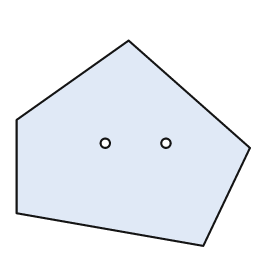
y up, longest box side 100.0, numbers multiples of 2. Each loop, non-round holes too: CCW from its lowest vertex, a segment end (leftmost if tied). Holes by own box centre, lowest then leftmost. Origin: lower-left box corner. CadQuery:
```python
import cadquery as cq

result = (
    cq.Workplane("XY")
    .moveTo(80.0, 0.0)
    .lineTo(100.0, 42.0)
    .lineTo(48.0, 88.0)
    .lineTo(0.0, 54.0)
    .lineTo(0.0, 14.0)
    .close()
    .moveTo(38.0, 44.0)
    .circle(2.0)
    .moveTo(64.0, 44.0)
    .circle(2.0)
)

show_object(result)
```